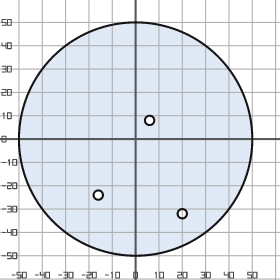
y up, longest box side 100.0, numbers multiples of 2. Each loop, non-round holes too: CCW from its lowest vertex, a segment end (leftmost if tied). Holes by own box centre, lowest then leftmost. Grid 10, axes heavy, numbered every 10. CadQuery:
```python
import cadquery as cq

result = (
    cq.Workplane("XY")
    .moveTo(0.0, 0.0)
    .circle(50.0)
    .moveTo(20.0, -32.0)
    .circle(2.0)
    .moveTo(-16.0, -24.0)
    .circle(2.0)
    .moveTo(6.0, 8.0)
    .circle(2.0)
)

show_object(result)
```